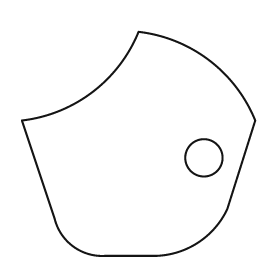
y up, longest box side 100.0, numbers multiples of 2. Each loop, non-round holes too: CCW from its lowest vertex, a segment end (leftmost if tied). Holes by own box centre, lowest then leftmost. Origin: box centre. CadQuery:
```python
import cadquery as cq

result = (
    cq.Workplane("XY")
    .moveTo(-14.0, -48.0)
    .lineTo(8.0, -48.0)
    .threePointArc((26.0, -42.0), (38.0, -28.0))
    .lineTo(50.0, 10.0)
    .threePointArc((30.0, 36.0), (0.0, 48.0))
    .threePointArc((-20.0, 22.0), (-50.0, 10.0))
    .lineTo(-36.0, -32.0)
    .threePointArc((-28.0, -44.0), (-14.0, -48.0))
    .close()
    .moveTo(28.0, -6.0)
    .circle(8.0)
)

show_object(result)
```